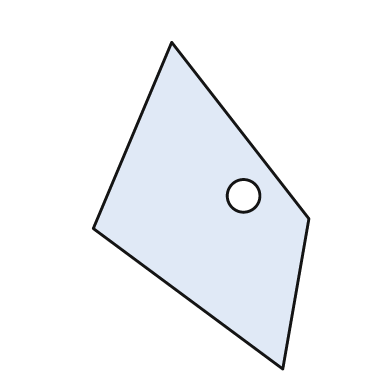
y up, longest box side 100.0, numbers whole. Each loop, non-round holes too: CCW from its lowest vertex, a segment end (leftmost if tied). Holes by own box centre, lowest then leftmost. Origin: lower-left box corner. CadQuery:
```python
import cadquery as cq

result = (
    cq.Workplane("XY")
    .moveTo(58.0, 0.0)
    .lineTo(66.0, 46.0)
    .lineTo(24.0, 100.0)
    .lineTo(0.0, 43.0)
    .close()
    .moveTo(46.0, 53.0)
    .circle(5.0)
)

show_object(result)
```